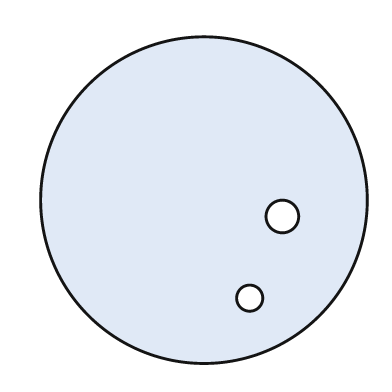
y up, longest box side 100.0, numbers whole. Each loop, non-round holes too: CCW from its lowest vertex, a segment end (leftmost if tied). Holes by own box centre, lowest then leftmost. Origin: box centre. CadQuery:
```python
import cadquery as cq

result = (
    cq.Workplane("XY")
    .moveTo(0.0, 0.0)
    .circle(50.0)
    .moveTo(14.0, -30.0)
    .circle(4.0)
    .moveTo(24.0, -5.0)
    .circle(5.0)
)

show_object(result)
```